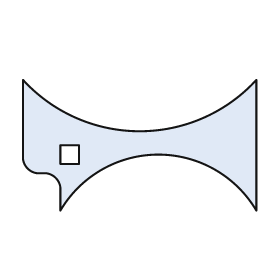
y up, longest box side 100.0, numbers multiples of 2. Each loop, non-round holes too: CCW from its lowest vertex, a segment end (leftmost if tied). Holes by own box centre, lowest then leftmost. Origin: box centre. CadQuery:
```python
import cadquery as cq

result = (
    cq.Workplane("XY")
    .moveTo(-34.0, -28.0)
    .threePointArc((8.0, -4.0), (50.0, -28.0))
    .lineTo(50.0, 28.0)
    .threePointArc((0.0, 6.0), (-50.0, 28.0))
    .lineTo(-50.0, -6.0)
    .threePointArc((-48.0, -10.0), (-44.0, -12.0))
    .lineTo(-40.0, -12.0)
    .threePointArc((-36.0, -14.0), (-34.0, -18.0))
    .close()
    .moveTo(-34.0, -8.0)
    .lineTo(-26.0, -8.0)
    .lineTo(-26.0, 0.0)
    .lineTo(-34.0, 0.0)
    .close()
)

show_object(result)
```